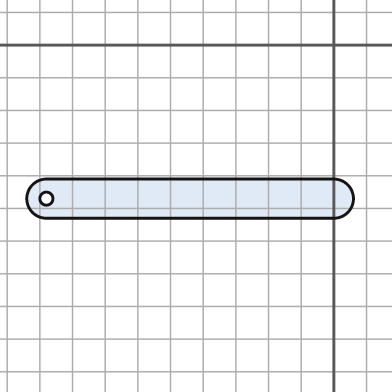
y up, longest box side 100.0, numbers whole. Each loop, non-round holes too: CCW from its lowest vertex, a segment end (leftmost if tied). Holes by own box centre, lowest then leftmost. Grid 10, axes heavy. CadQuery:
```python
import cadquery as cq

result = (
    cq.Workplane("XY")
    .moveTo(-88.0, -53.0)
    .lineTo(0.0, -53.0)
    .threePointArc((6.0, -47.0), (0.0, -41.0))
    .lineTo(-88.0, -41.0)
    .threePointArc((-94.0, -47.0), (-88.0, -53.0))
    .close()
    .moveTo(-88.0, -47.0)
    .circle(2.0)
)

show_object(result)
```